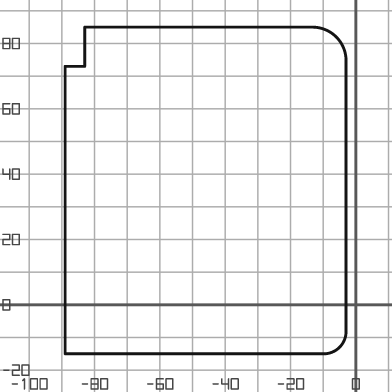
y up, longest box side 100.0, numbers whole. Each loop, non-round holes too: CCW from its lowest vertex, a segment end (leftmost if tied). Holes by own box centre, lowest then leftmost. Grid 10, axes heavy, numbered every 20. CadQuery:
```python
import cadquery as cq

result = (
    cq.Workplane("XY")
    .moveTo(-89.0, -15.0)
    .lineTo(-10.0, -15.0)
    .threePointArc((-5.0, -13.0), (-3.0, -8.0))
    .lineTo(-3.0, 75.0)
    .threePointArc((-6.0, 82.0), (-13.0, 85.0))
    .lineTo(-83.0, 85.0)
    .lineTo(-83.0, 73.0)
    .lineTo(-89.0, 73.0)
    .close()
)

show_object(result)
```